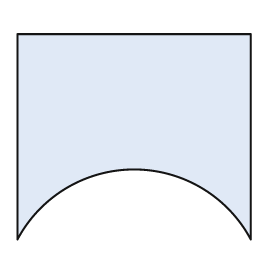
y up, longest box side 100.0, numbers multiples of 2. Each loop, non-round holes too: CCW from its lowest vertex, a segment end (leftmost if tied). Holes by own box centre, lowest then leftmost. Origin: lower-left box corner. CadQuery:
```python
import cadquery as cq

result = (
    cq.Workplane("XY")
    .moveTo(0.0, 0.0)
    .threePointArc((50.0, 30.0), (100.0, 0.0))
    .lineTo(100.0, 88.0)
    .lineTo(0.0, 88.0)
    .close()
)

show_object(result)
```